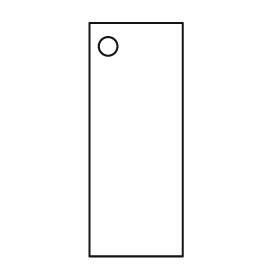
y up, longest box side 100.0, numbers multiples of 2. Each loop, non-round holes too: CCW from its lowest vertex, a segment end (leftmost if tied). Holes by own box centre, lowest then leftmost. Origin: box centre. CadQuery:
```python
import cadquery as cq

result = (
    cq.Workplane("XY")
    .moveTo(-20.0, -50.0)
    .lineTo(20.0, -50.0)
    .lineTo(20.0, 50.0)
    .lineTo(-20.0, 50.0)
    .close()
    .moveTo(-12.0, 40.0)
    .circle(4.0)
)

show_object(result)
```